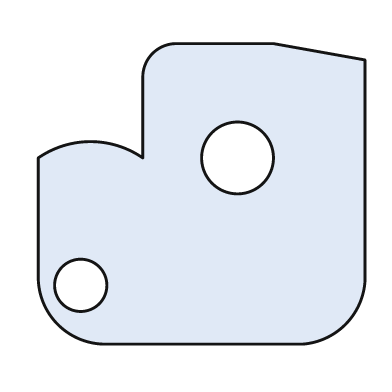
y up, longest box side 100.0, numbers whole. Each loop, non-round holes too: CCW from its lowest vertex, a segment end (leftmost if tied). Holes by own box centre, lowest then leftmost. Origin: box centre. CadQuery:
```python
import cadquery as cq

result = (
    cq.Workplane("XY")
    .moveTo(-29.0, -46.0)
    .lineTo(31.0, -46.0)
    .threePointArc((44.0, -40.0), (50.0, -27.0))
    .lineTo(50.0, 41.0)
    .lineTo(22.0, 46.0)
    .lineTo(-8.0, 46.0)
    .threePointArc((-15.0, 43.0), (-18.0, 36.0))
    .lineTo(-18.0, 11.0)
    .threePointArc((-34.0, 16.0), (-50.0, 11.0))
    .lineTo(-50.0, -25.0)
    .threePointArc((-44.0, -40.0), (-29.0, -46.0))
    .close()
    .moveTo(-37.0, -28.0)
    .circle(8.0)
    .moveTo(11.0, 11.0)
    .circle(11.0)
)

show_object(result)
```